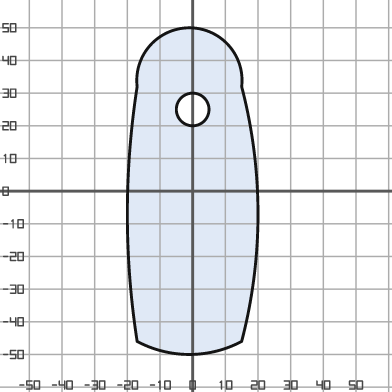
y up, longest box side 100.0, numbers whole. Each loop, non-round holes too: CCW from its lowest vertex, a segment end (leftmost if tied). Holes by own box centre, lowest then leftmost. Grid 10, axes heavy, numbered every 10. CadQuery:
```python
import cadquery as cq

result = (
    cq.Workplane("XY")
    .moveTo(-17.0, -46.0)
    .threePointArc((-1.0, -50.0), (15.0, -46.0))
    .threePointArc((20.0, -7.0), (15.0, 32.0))
    .threePointArc((-1.0, 50.0), (-17.0, 32.0))
    .threePointArc((-20.0, -7.0), (-17.0, -46.0))
    .close()
    .moveTo(0.0, 25.0)
    .circle(5.0)
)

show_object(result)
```